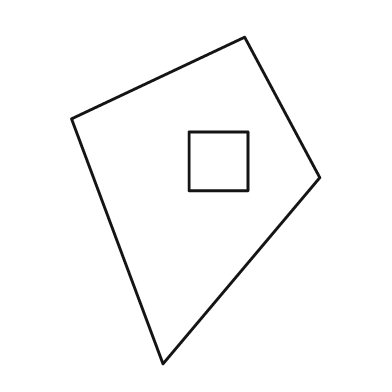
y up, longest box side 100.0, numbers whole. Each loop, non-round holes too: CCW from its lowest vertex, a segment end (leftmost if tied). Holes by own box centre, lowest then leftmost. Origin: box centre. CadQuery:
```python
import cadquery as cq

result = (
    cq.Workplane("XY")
    .moveTo(-10.0, -50.0)
    .lineTo(38.0, 7.0)
    .lineTo(15.0, 50.0)
    .lineTo(-38.0, 25.0)
    .close()
    .moveTo(-2.0, 3.0)
    .lineTo(16.0, 3.0)
    .lineTo(16.0, 21.0)
    .lineTo(-2.0, 21.0)
    .close()
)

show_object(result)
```